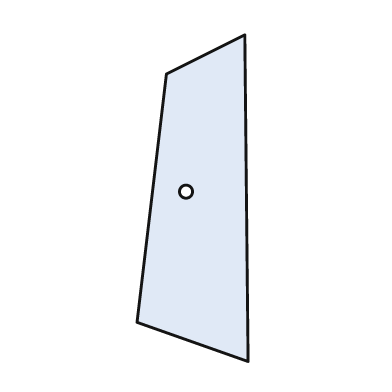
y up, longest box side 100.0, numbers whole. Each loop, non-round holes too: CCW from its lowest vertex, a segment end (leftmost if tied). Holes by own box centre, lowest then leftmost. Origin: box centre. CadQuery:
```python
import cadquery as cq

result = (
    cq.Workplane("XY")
    .moveTo(17.0, -50.0)
    .lineTo(16.0, 50.0)
    .lineTo(-8.0, 38.0)
    .lineTo(-17.0, -38.0)
    .close()
    .moveTo(-2.0, 2.0)
    .circle(2.0)
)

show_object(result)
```